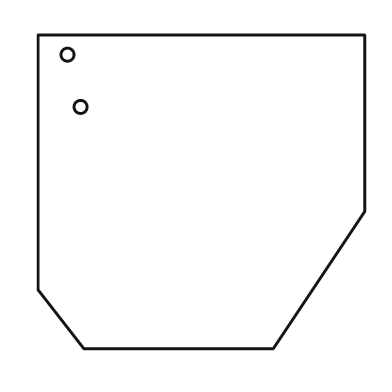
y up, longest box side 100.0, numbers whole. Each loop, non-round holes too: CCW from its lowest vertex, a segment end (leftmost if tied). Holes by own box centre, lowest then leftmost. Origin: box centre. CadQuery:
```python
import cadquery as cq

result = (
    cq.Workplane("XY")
    .moveTo(-36.0, -48.0)
    .lineTo(22.0, -48.0)
    .lineTo(50.0, -6.0)
    .lineTo(50.0, 48.0)
    .lineTo(-50.0, 48.0)
    .lineTo(-50.0, -30.0)
    .close()
    .moveTo(-37.0, 26.0)
    .circle(2.0)
    .moveTo(-41.0, 42.0)
    .circle(2.0)
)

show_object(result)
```